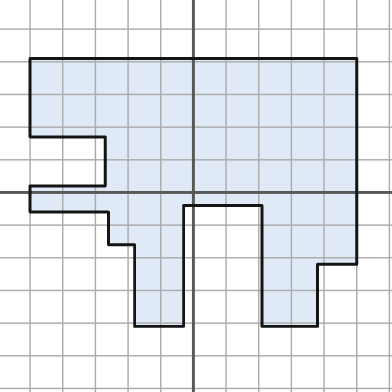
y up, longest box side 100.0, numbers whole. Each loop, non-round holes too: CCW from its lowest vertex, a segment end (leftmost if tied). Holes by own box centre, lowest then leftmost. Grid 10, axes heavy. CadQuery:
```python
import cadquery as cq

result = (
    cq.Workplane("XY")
    .moveTo(-18.0, -41.0)
    .lineTo(-3.0, -41.0)
    .lineTo(-3.0, -4.0)
    .lineTo(21.0, -4.0)
    .lineTo(21.0, -41.0)
    .lineTo(38.0, -41.0)
    .lineTo(38.0, -22.0)
    .lineTo(50.0, -22.0)
    .lineTo(50.0, 41.0)
    .lineTo(-50.0, 41.0)
    .lineTo(-50.0, 17.0)
    .lineTo(-27.0, 17.0)
    .lineTo(-27.0, 2.0)
    .lineTo(-50.0, 2.0)
    .lineTo(-50.0, -6.0)
    .lineTo(-26.0, -6.0)
    .lineTo(-26.0, -16.0)
    .lineTo(-18.0, -16.0)
    .close()
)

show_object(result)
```